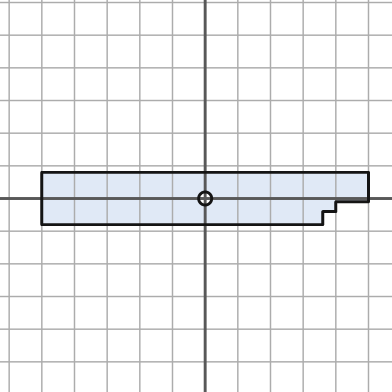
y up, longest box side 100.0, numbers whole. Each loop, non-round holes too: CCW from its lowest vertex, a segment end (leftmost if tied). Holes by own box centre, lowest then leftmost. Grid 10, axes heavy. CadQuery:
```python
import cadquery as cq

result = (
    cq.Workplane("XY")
    .moveTo(-50.0, -8.0)
    .lineTo(36.0, -8.0)
    .lineTo(36.0, -4.0)
    .lineTo(40.0, -4.0)
    .lineTo(40.0, -1.0)
    .lineTo(50.0, -1.0)
    .lineTo(50.0, 8.0)
    .lineTo(-50.0, 8.0)
    .close()
    .moveTo(0.0, 0.0)
    .circle(2.0)
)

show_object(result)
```